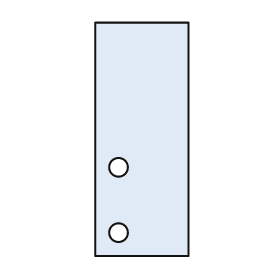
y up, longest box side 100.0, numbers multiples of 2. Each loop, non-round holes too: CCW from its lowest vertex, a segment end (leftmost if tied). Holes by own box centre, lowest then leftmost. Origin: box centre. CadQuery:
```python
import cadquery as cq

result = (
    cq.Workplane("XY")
    .moveTo(-20.0, -50.0)
    .lineTo(20.0, -50.0)
    .lineTo(20.0, 50.0)
    .lineTo(-20.0, 50.0)
    .close()
    .moveTo(-10.0, -40.0)
    .circle(4.0)
    .moveTo(-10.0, -12.0)
    .circle(4.0)
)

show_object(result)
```